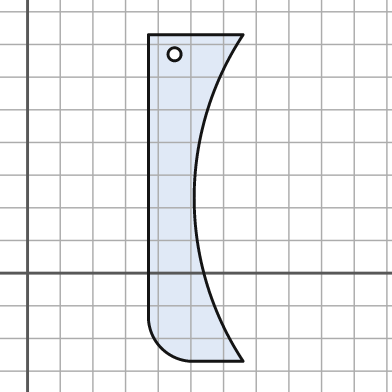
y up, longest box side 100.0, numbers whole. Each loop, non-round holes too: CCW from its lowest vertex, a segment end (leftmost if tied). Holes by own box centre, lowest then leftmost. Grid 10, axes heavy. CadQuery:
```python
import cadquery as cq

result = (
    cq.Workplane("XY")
    .moveTo(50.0, -27.0)
    .lineTo(66.0, -27.0)
    .threePointArc((51.0, 23.0), (66.0, 73.0))
    .lineTo(37.0, 73.0)
    .lineTo(37.0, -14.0)
    .threePointArc((41.0, -23.0), (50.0, -27.0))
    .close()
    .moveTo(45.0, 67.0)
    .circle(2.0)
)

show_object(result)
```